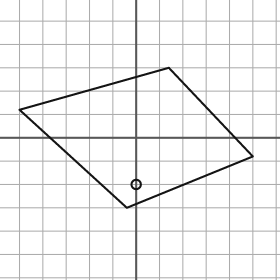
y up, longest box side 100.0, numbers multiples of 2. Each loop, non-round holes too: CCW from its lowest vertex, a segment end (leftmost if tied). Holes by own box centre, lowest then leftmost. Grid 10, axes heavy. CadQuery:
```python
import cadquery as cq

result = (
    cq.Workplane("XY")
    .moveTo(-4.0, -30.0)
    .lineTo(50.0, -8.0)
    .lineTo(14.0, 30.0)
    .lineTo(-50.0, 12.0)
    .close()
    .moveTo(0.0, -20.0)
    .circle(2.0)
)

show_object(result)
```